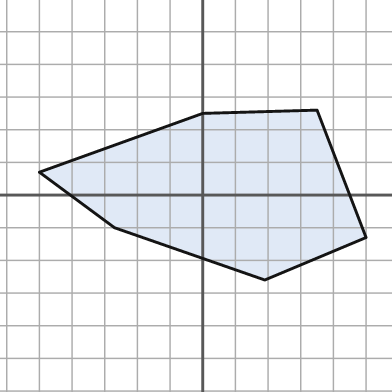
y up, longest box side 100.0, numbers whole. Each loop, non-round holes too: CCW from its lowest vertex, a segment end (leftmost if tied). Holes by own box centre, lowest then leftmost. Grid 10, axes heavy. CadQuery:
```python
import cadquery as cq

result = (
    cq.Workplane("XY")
    .moveTo(19.0, -26.0)
    .lineTo(50.0, -13.0)
    .lineTo(35.0, 26.0)
    .lineTo(0.0, 25.0)
    .lineTo(-50.0, 7.0)
    .lineTo(-27.0, -10.0)
    .close()
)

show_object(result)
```